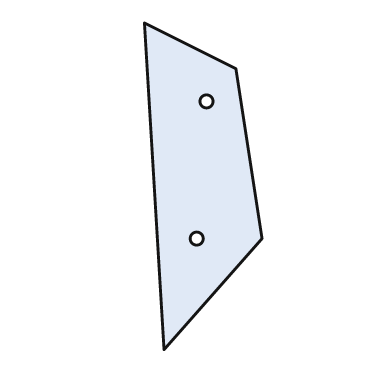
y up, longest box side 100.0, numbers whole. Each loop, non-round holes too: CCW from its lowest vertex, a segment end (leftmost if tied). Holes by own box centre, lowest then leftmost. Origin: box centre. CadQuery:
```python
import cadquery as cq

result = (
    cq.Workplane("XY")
    .moveTo(-12.0, -50.0)
    .lineTo(18.0, -16.0)
    .lineTo(10.0, 36.0)
    .lineTo(-18.0, 50.0)
    .close()
    .moveTo(-2.0, -16.0)
    .circle(2.0)
    .moveTo(1.0, 26.0)
    .circle(2.0)
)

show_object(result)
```